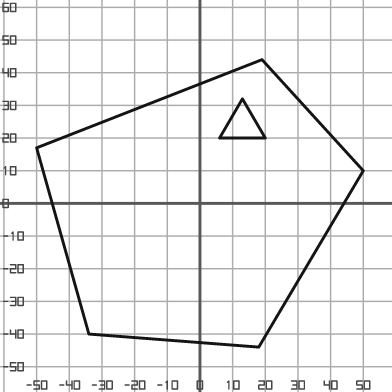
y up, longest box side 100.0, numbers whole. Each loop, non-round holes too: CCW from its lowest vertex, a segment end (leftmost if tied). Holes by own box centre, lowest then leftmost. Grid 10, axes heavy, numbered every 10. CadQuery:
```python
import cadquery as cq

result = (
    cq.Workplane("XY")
    .moveTo(18.0, -44.0)
    .lineTo(50.0, 10.0)
    .lineTo(19.0, 44.0)
    .lineTo(-50.0, 17.0)
    .lineTo(-34.0, -40.0)
    .close()
    .moveTo(6.0, 20.0)
    .lineTo(20.0, 20.0)
    .lineTo(13.0, 32.0)
    .close()
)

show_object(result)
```